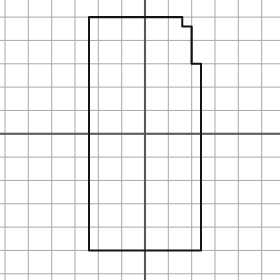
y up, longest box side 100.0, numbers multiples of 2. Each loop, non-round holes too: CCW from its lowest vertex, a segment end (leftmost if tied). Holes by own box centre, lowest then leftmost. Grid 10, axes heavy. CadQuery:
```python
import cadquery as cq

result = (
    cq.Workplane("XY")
    .moveTo(-24.0, -50.0)
    .lineTo(24.0, -50.0)
    .lineTo(24.0, 30.0)
    .lineTo(20.0, 30.0)
    .lineTo(20.0, 46.0)
    .lineTo(16.0, 46.0)
    .lineTo(16.0, 50.0)
    .lineTo(-24.0, 50.0)
    .close()
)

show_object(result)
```